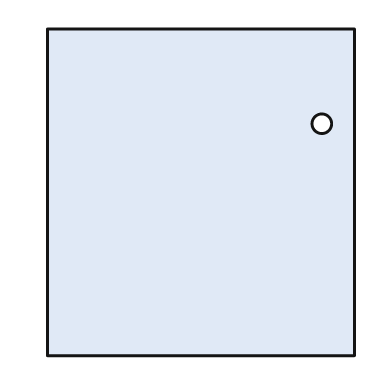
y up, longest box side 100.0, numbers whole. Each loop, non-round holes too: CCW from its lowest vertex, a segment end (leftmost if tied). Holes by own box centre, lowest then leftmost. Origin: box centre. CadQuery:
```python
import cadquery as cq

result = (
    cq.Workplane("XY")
    .moveTo(-47.0, -50.0)
    .lineTo(47.0, -50.0)
    .lineTo(47.0, 50.0)
    .lineTo(-47.0, 50.0)
    .close()
    .moveTo(37.0, 21.0)
    .circle(3.0)
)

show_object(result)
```